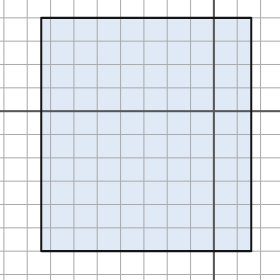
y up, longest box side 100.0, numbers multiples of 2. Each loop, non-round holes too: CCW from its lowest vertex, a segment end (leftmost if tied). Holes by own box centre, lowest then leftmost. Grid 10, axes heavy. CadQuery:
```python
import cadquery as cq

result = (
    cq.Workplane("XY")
    .moveTo(-74.0, -60.0)
    .lineTo(16.0, -60.0)
    .lineTo(16.0, 40.0)
    .lineTo(-74.0, 40.0)
    .close()
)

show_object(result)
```